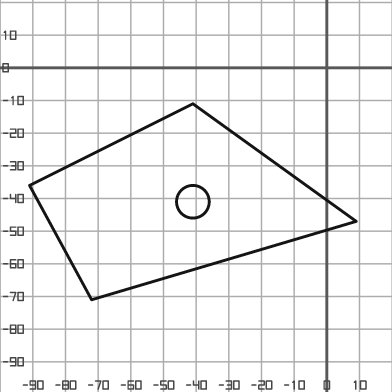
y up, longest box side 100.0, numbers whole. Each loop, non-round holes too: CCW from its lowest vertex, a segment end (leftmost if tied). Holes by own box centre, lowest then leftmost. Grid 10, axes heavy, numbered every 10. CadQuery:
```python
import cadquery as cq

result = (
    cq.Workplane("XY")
    .moveTo(-72.0, -71.0)
    .lineTo(9.0, -47.0)
    .lineTo(-41.0, -11.0)
    .lineTo(-91.0, -36.0)
    .close()
    .moveTo(-41.0, -41.0)
    .circle(5.0)
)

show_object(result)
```